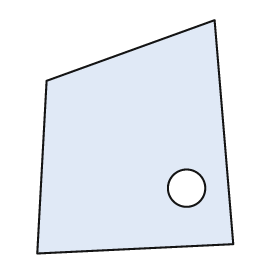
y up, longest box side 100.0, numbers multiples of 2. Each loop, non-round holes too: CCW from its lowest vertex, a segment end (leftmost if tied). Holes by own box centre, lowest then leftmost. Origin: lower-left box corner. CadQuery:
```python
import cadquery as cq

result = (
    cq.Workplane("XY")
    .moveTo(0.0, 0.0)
    .lineTo(84.0, 4.0)
    .lineTo(76.0, 100.0)
    .lineTo(4.0, 74.0)
    .close()
    .moveTo(64.0, 28.0)
    .circle(8.0)
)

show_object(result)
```